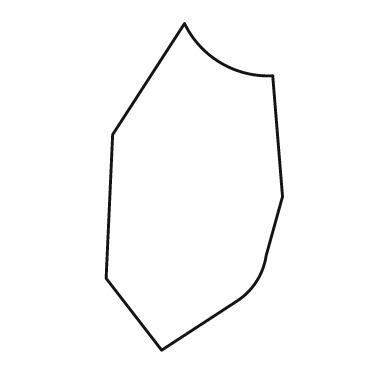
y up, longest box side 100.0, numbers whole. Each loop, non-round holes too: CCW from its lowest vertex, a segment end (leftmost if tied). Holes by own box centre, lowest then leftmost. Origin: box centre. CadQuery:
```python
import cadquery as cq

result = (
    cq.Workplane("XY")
    .moveTo(-10.0, -50.0)
    .lineTo(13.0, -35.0)
    .threePointArc((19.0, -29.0), (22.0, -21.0))
    .lineTo(27.0, -3.0)
    .lineTo(24.0, 34.0)
    .threePointArc((8.0, 38.0), (-3.0, 50.0))
    .lineTo(-25.0, 16.0)
    .lineTo(-27.0, -28.0)
    .close()
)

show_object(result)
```